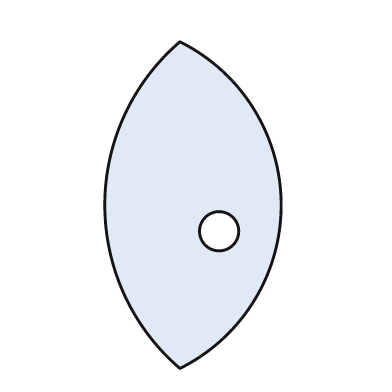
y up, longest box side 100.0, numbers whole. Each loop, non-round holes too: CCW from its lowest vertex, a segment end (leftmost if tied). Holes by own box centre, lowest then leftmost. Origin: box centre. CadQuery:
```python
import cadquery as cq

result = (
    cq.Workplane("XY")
    .moveTo(-4.0, -50.0)
    .threePointArc((27.0, 0.0), (-4.0, 50.0))
    .threePointArc((-27.0, 0.0), (-4.0, -50.0))
    .close()
    .moveTo(8.0, -8.0)
    .circle(6.0)
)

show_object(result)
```